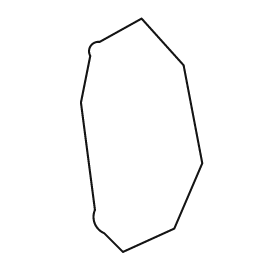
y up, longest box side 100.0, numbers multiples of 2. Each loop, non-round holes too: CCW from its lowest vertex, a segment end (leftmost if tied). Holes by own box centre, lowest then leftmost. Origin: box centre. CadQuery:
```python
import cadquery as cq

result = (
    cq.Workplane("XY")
    .moveTo(-8.0, -50.0)
    .lineTo(14.0, -40.0)
    .lineTo(26.0, -12.0)
    .lineTo(18.0, 30.0)
    .lineTo(0.0, 50.0)
    .lineTo(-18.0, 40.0)
    .threePointArc((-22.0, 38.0), (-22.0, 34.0))
    .lineTo(-26.0, 14.0)
    .lineTo(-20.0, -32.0)
    .threePointArc((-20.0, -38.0), (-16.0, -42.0))
    .close()
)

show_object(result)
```